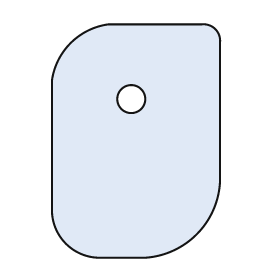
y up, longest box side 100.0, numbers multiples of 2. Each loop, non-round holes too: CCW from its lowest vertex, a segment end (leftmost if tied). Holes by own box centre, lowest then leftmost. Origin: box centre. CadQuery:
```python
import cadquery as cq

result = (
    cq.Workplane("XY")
    .moveTo(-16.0, -50.0)
    .lineTo(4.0, -50.0)
    .threePointArc((26.0, -40.0), (36.0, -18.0))
    .lineTo(36.0, 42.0)
    .threePointArc((34.0, 48.0), (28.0, 50.0))
    .lineTo(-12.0, 50.0)
    .threePointArc((-28.0, 42.0), (-36.0, 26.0))
    .lineTo(-36.0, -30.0)
    .threePointArc((-30.0, -44.0), (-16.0, -50.0))
    .close()
    .moveTo(-2.0, 18.0)
    .circle(6.0)
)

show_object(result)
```